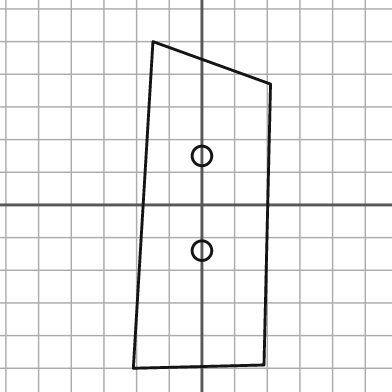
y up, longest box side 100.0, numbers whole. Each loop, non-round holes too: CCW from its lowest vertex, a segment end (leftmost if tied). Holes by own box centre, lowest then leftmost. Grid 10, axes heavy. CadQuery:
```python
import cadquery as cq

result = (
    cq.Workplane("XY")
    .moveTo(-21.0, -50.0)
    .lineTo(19.0, -49.0)
    .lineTo(21.0, 37.0)
    .lineTo(-15.0, 50.0)
    .close()
    .moveTo(0.0, -14.0)
    .circle(3.0)
    .moveTo(0.0, 15.0)
    .circle(3.0)
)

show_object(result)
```